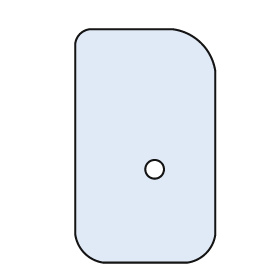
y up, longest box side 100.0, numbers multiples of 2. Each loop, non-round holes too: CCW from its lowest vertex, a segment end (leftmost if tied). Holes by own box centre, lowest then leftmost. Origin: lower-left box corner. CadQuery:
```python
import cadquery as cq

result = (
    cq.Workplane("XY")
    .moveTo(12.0, 0.0)
    .lineTo(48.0, 0.0)
    .threePointArc((56.0, 4.0), (60.0, 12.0))
    .lineTo(60.0, 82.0)
    .threePointArc((54.0, 94.0), (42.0, 100.0))
    .lineTo(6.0, 100.0)
    .threePointArc((2.0, 98.0), (0.0, 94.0))
    .lineTo(0.0, 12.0)
    .threePointArc((4.0, 4.0), (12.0, 0.0))
    .close()
    .moveTo(34.0, 40.0)
    .circle(4.0)
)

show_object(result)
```